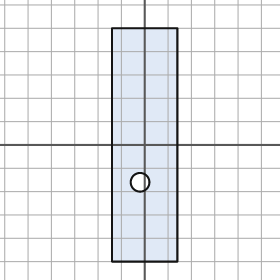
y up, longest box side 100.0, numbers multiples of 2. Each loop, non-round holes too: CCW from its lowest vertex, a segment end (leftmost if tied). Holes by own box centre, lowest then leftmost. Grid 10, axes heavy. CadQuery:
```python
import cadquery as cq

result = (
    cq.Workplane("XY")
    .moveTo(-14.0, -50.0)
    .lineTo(14.0, -50.0)
    .lineTo(14.0, 50.0)
    .lineTo(-14.0, 50.0)
    .close()
    .moveTo(-2.0, -16.0)
    .circle(4.0)
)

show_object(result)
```